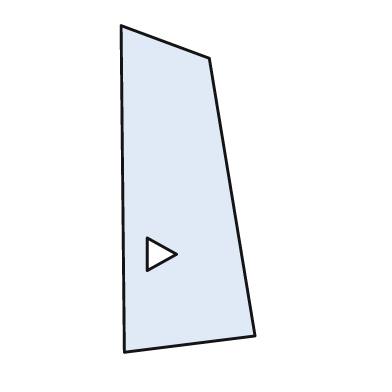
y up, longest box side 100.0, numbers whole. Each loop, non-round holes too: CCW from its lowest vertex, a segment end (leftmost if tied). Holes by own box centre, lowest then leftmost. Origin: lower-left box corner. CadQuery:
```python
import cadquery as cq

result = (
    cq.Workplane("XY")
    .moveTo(1.0, 0.0)
    .lineTo(41.0, 5.0)
    .lineTo(27.0, 90.0)
    .lineTo(0.0, 100.0)
    .close()
    .moveTo(8.0, 25.0)
    .lineTo(17.0, 30.0)
    .lineTo(8.0, 35.0)
    .close()
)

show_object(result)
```